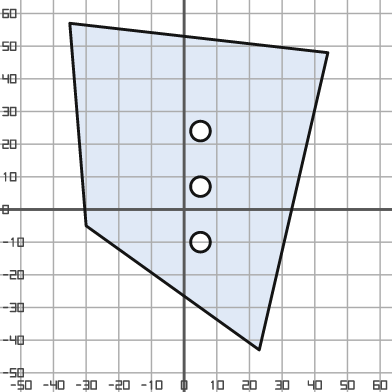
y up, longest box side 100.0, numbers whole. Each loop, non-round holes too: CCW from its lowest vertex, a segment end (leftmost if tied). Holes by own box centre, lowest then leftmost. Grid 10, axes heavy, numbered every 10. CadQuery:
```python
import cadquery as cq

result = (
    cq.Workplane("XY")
    .moveTo(23.0, -43.0)
    .lineTo(44.0, 48.0)
    .lineTo(-35.0, 57.0)
    .lineTo(-30.0, -5.0)
    .close()
    .moveTo(5.0, -10.0)
    .circle(3.0)
    .moveTo(5.0, 7.0)
    .circle(3.0)
    .moveTo(5.0, 24.0)
    .circle(3.0)
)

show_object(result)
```